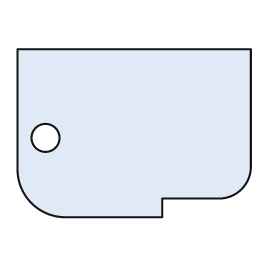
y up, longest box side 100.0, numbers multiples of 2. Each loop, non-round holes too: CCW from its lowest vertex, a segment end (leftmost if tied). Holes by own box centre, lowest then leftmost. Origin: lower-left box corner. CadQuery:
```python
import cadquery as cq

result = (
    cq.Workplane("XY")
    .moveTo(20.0, 0.0)
    .lineTo(62.0, 0.0)
    .lineTo(62.0, 8.0)
    .lineTo(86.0, 8.0)
    .threePointArc((96.0, 12.0), (100.0, 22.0))
    .lineTo(100.0, 72.0)
    .lineTo(0.0, 72.0)
    .lineTo(0.0, 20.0)
    .threePointArc((6.0, 6.0), (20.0, 0.0))
    .close()
    .moveTo(12.0, 34.0)
    .circle(6.0)
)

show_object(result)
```